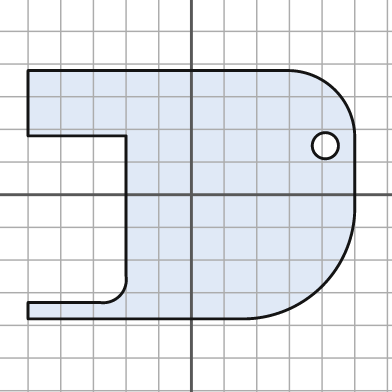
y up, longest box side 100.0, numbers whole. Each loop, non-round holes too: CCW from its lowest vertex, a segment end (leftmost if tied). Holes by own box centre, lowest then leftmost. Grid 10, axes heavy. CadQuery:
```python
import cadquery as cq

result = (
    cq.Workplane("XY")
    .moveTo(-50.0, -38.0)
    .lineTo(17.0, -38.0)
    .threePointArc((40.0, -28.0), (50.0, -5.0))
    .lineTo(50.0, 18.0)
    .threePointArc((44.0, 32.0), (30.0, 38.0))
    .lineTo(-50.0, 38.0)
    .lineTo(-50.0, 18.0)
    .lineTo(-20.0, 18.0)
    .lineTo(-20.0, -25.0)
    .threePointArc((-22.0, -31.0), (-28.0, -33.0))
    .lineTo(-50.0, -33.0)
    .close()
    .moveTo(41.0, 15.0)
    .circle(4.0)
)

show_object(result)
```